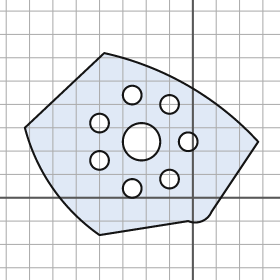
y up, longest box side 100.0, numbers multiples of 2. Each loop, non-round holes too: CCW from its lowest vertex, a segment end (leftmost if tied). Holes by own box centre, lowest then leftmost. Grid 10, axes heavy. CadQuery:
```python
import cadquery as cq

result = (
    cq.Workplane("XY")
    .moveTo(-40.0, -16.0)
    .lineTo(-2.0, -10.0)
    .threePointArc((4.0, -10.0), (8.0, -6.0))
    .lineTo(28.0, 24.0)
    .threePointArc((-2.0, 48.0), (-38.0, 62.0))
    .lineTo(-72.0, 30.0)
    .threePointArc((-60.0, 4.0), (-40.0, -16.0))
    .close()
    .moveTo(-26.0, 4.0)
    .circle(4.0)
    .moveTo(-10.0, 8.0)
    .circle(4.0)
    .moveTo(-40.0, 16.0)
    .circle(4.0)
    .moveTo(-22.0, 24.0)
    .circle(8.0)
    .moveTo(-2.0, 24.0)
    .circle(4.0)
    .moveTo(-40.0, 32.0)
    .circle(4.0)
    .moveTo(-10.0, 40.0)
    .circle(4.0)
    .moveTo(-26.0, 44.0)
    .circle(4.0)
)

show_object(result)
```